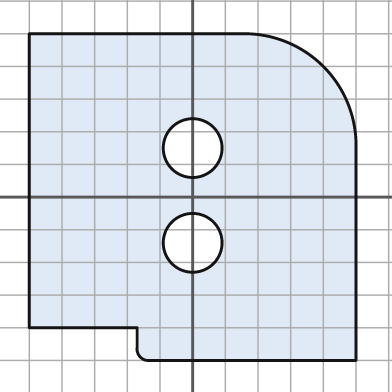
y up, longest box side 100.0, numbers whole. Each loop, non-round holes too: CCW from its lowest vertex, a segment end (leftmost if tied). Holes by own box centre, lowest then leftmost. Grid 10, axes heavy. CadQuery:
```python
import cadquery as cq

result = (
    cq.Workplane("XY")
    .moveTo(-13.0, -50.0)
    .lineTo(50.0, -50.0)
    .lineTo(50.0, 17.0)
    .threePointArc((40.0, 40.0), (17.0, 50.0))
    .lineTo(-50.0, 50.0)
    .lineTo(-50.0, -40.0)
    .lineTo(-17.0, -40.0)
    .lineTo(-17.0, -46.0)
    .threePointArc((-16.0, -49.0), (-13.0, -50.0))
    .close()
    .moveTo(0.0, -14.0)
    .circle(9.0)
    .moveTo(0.0, 15.0)
    .circle(9.0)
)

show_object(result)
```